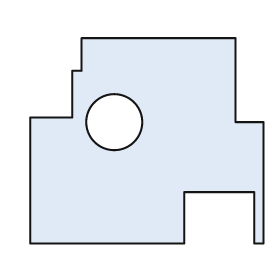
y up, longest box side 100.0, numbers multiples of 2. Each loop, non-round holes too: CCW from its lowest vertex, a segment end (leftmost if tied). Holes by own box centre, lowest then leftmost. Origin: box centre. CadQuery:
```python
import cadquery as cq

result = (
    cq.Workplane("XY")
    .moveTo(-50.0, -44.0)
    .lineTo(16.0, -44.0)
    .lineTo(16.0, -22.0)
    .lineTo(46.0, -22.0)
    .lineTo(46.0, -44.0)
    .lineTo(50.0, -44.0)
    .lineTo(50.0, 8.0)
    .lineTo(38.0, 8.0)
    .lineTo(38.0, 44.0)
    .lineTo(-28.0, 44.0)
    .lineTo(-28.0, 30.0)
    .lineTo(-32.0, 30.0)
    .lineTo(-32.0, 10.0)
    .lineTo(-50.0, 10.0)
    .close()
    .moveTo(-14.0, 8.0)
    .circle(12.0)
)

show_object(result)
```